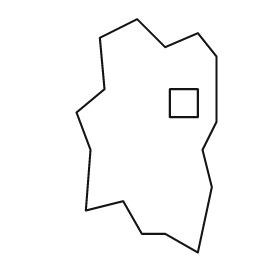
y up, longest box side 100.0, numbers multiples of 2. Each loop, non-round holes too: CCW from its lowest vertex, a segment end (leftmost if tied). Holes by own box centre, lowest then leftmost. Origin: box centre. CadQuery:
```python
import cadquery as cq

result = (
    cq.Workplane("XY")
    .moveTo(22.0, -50.0)
    .lineTo(28.0, -22.0)
    .lineTo(24.0, -6.0)
    .lineTo(30.0, 6.0)
    .lineTo(30.0, 34.0)
    .lineTo(22.0, 44.0)
    .lineTo(8.0, 38.0)
    .lineTo(-4.0, 50.0)
    .lineTo(-20.0, 42.0)
    .lineTo(-18.0, 20.0)
    .lineTo(-30.0, 10.0)
    .lineTo(-24.0, -6.0)
    .lineTo(-26.0, -32.0)
    .lineTo(-10.0, -28.0)
    .lineTo(-2.0, -42.0)
    .lineTo(8.0, -42.0)
    .close()
    .moveTo(10.0, 8.0)
    .lineTo(22.0, 8.0)
    .lineTo(22.0, 20.0)
    .lineTo(10.0, 20.0)
    .close()
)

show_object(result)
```